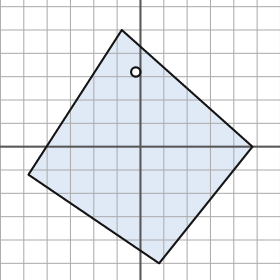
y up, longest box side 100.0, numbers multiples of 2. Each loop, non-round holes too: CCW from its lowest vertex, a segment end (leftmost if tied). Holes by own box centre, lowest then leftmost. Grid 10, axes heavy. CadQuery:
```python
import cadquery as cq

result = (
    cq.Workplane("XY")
    .moveTo(8.0, -50.0)
    .lineTo(48.0, 0.0)
    .lineTo(-8.0, 50.0)
    .lineTo(-48.0, -12.0)
    .close()
    .moveTo(-2.0, 32.0)
    .circle(2.0)
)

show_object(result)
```